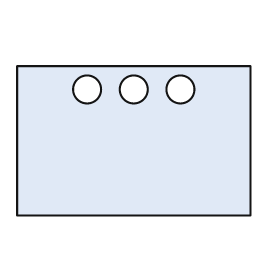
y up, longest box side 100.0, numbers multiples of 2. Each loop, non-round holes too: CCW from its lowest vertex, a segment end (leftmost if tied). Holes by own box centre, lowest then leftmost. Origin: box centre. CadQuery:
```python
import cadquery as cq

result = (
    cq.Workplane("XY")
    .moveTo(-50.0, -32.0)
    .lineTo(50.0, -32.0)
    .lineTo(50.0, 32.0)
    .lineTo(-50.0, 32.0)
    .close()
    .moveTo(-20.0, 22.0)
    .circle(6.0)
    .moveTo(0.0, 22.0)
    .circle(6.0)
    .moveTo(20.0, 22.0)
    .circle(6.0)
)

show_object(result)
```